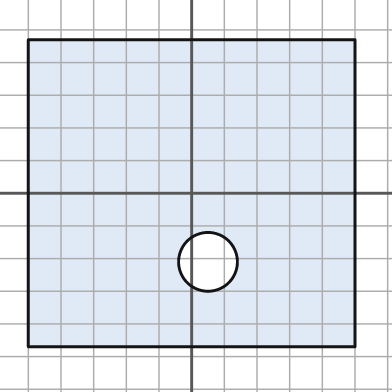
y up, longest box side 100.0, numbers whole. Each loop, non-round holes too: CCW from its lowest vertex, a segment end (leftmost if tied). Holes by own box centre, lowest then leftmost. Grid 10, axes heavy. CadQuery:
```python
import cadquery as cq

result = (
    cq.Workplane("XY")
    .moveTo(-50.0, -47.0)
    .lineTo(50.0, -47.0)
    .lineTo(50.0, 47.0)
    .lineTo(-50.0, 47.0)
    .close()
    .moveTo(5.0, -21.0)
    .circle(9.0)
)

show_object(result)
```